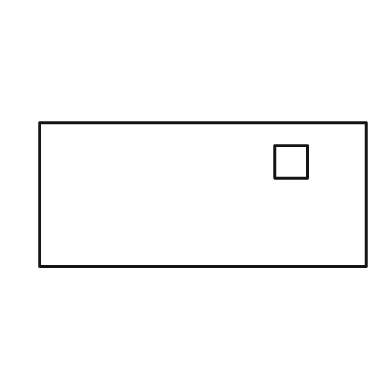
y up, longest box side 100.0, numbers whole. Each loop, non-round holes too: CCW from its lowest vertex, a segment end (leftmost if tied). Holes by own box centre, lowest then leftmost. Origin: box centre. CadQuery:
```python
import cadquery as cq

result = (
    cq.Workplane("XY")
    .moveTo(-50.0, -22.0)
    .lineTo(50.0, -22.0)
    .lineTo(50.0, 22.0)
    .lineTo(-50.0, 22.0)
    .close()
    .moveTo(22.0, 5.0)
    .lineTo(32.0, 5.0)
    .lineTo(32.0, 15.0)
    .lineTo(22.0, 15.0)
    .close()
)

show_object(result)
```